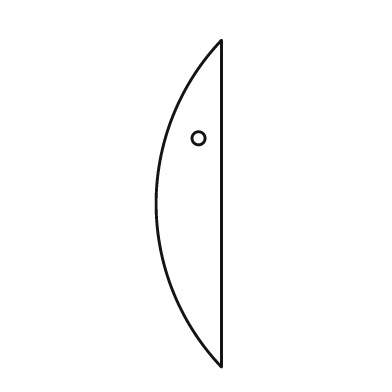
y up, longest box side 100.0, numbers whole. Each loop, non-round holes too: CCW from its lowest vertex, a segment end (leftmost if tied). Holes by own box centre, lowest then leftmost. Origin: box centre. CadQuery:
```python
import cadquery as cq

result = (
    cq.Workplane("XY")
    .moveTo(10.0, -50.0)
    .lineTo(10.0, 50.0)
    .threePointArc((-10.0, 0.0), (10.0, -50.0))
    .close()
    .moveTo(3.0, 20.0)
    .circle(2.0)
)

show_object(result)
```